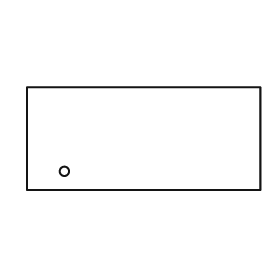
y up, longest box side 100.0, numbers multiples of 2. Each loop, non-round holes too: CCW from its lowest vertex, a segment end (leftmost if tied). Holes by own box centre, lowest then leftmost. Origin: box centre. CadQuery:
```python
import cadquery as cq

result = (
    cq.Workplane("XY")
    .moveTo(-50.0, -22.0)
    .lineTo(50.0, -22.0)
    .lineTo(50.0, 22.0)
    .lineTo(-50.0, 22.0)
    .close()
    .moveTo(-34.0, -14.0)
    .circle(2.0)
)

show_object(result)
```